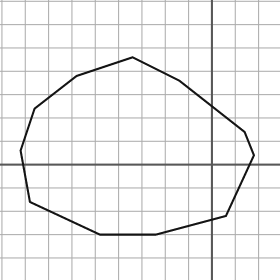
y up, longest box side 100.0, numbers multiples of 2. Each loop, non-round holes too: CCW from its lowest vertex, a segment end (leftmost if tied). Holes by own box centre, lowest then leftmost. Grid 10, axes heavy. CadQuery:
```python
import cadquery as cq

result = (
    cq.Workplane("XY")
    .moveTo(-48.0, -30.0)
    .lineTo(-24.0, -30.0)
    .lineTo(6.0, -22.0)
    .lineTo(18.0, 4.0)
    .lineTo(14.0, 14.0)
    .lineTo(-14.0, 36.0)
    .lineTo(-34.0, 46.0)
    .lineTo(-58.0, 38.0)
    .lineTo(-76.0, 24.0)
    .lineTo(-82.0, 6.0)
    .lineTo(-78.0, -16.0)
    .close()
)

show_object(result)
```